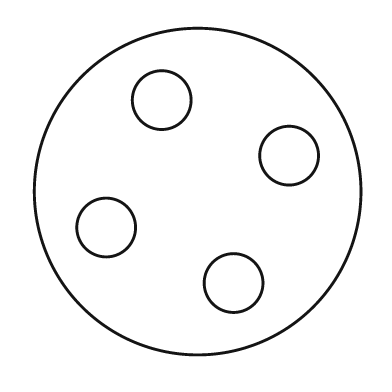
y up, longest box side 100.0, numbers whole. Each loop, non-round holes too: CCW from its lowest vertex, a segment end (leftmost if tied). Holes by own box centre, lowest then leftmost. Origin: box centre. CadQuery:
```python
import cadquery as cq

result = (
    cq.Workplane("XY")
    .moveTo(0.0, 0.0)
    .circle(50.0)
    .moveTo(11.0, -28.0)
    .circle(9.0)
    .moveTo(-28.0, -11.0)
    .circle(9.0)
    .moveTo(28.0, 11.0)
    .circle(9.0)
    .moveTo(-11.0, 28.0)
    .circle(9.0)
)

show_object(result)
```